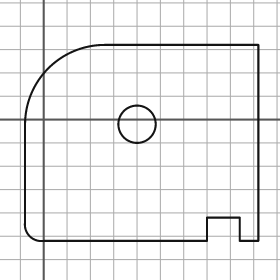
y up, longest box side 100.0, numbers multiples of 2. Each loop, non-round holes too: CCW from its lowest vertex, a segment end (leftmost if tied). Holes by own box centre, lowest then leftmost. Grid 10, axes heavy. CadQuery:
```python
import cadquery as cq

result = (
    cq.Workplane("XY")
    .moveTo(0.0, -52.0)
    .lineTo(70.0, -52.0)
    .lineTo(70.0, -42.0)
    .lineTo(84.0, -42.0)
    .lineTo(84.0, -52.0)
    .lineTo(92.0, -52.0)
    .lineTo(92.0, 32.0)
    .lineTo(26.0, 32.0)
    .threePointArc((2.0, 22.0), (-8.0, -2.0))
    .lineTo(-8.0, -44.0)
    .threePointArc((-6.0, -50.0), (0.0, -52.0))
    .close()
    .moveTo(40.0, -2.0)
    .circle(8.0)
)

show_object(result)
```